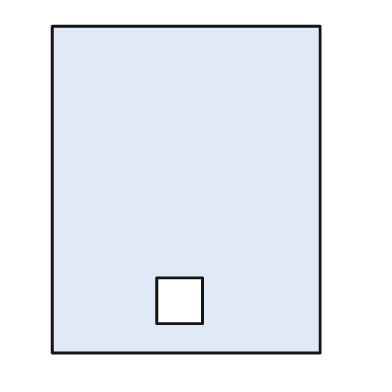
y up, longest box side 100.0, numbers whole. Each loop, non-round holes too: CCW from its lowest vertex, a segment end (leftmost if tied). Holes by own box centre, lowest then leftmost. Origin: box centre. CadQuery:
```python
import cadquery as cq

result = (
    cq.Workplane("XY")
    .moveTo(-41.0, -50.0)
    .lineTo(41.0, -50.0)
    .lineTo(41.0, 50.0)
    .lineTo(-41.0, 50.0)
    .close()
    .moveTo(-9.0, -41.0)
    .lineTo(5.0, -41.0)
    .lineTo(5.0, -27.0)
    .lineTo(-9.0, -27.0)
    .close()
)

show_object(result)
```